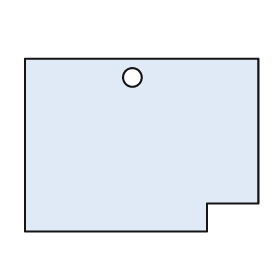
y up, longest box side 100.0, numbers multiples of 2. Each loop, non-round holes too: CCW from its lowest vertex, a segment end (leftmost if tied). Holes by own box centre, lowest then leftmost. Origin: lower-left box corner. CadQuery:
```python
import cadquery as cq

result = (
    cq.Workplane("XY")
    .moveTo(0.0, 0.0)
    .lineTo(78.0, 0.0)
    .lineTo(78.0, 12.0)
    .lineTo(100.0, 12.0)
    .lineTo(100.0, 74.0)
    .lineTo(0.0, 74.0)
    .close()
    .moveTo(46.0, 66.0)
    .circle(4.0)
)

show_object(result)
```